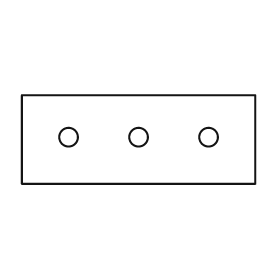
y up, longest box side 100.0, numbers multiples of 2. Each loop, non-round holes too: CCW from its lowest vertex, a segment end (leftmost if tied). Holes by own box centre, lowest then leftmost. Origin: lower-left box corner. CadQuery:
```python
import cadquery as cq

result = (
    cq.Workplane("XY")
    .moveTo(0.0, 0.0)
    .lineTo(100.0, 0.0)
    .lineTo(100.0, 38.0)
    .lineTo(0.0, 38.0)
    .close()
    .moveTo(20.0, 20.0)
    .circle(4.0)
    .moveTo(50.0, 20.0)
    .circle(4.0)
    .moveTo(80.0, 20.0)
    .circle(4.0)
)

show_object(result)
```